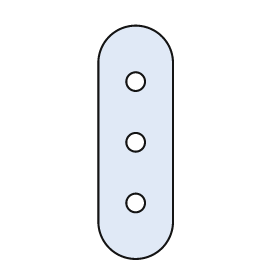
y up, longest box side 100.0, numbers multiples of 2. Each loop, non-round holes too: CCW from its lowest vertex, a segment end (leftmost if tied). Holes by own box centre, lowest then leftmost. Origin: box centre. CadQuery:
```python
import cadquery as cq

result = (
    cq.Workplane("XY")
    .moveTo(-16.0, -34.0)
    .threePointArc((0.0, -50.0), (16.0, -34.0))
    .lineTo(16.0, 34.0)
    .threePointArc((0.0, 50.0), (-16.0, 34.0))
    .close()
    .moveTo(0.0, -26.0)
    .circle(4.0)
    .moveTo(0.0, 0.0)
    .circle(4.0)
    .moveTo(0.0, 26.0)
    .circle(4.0)
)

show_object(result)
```